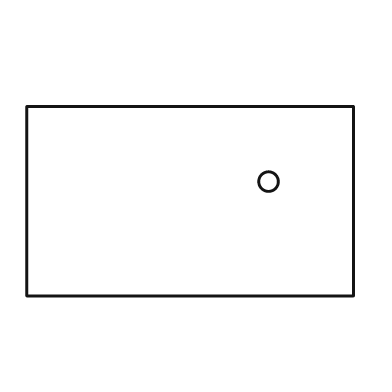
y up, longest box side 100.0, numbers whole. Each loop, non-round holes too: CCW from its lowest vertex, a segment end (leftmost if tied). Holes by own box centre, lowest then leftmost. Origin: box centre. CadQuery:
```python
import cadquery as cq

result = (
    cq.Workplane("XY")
    .moveTo(-50.0, -29.0)
    .lineTo(50.0, -29.0)
    .lineTo(50.0, 29.0)
    .lineTo(-50.0, 29.0)
    .close()
    .moveTo(24.0, 6.0)
    .circle(3.0)
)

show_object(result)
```